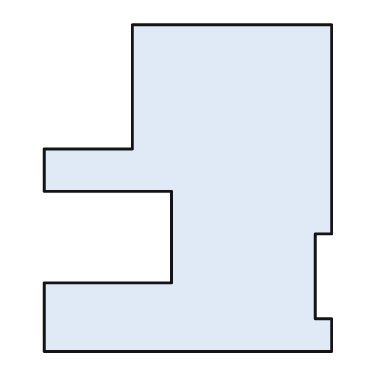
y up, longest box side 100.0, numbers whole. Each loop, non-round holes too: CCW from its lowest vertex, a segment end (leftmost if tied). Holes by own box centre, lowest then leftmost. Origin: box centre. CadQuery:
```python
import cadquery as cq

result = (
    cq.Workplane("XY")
    .moveTo(-44.0, -50.0)
    .lineTo(44.0, -50.0)
    .lineTo(44.0, -40.0)
    .lineTo(39.0, -40.0)
    .lineTo(39.0, -14.0)
    .lineTo(44.0, -14.0)
    .lineTo(44.0, 50.0)
    .lineTo(-17.0, 50.0)
    .lineTo(-17.0, 12.0)
    .lineTo(-44.0, 12.0)
    .lineTo(-44.0, -1.0)
    .lineTo(-5.0, -1.0)
    .lineTo(-5.0, -29.0)
    .lineTo(-44.0, -29.0)
    .close()
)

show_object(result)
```